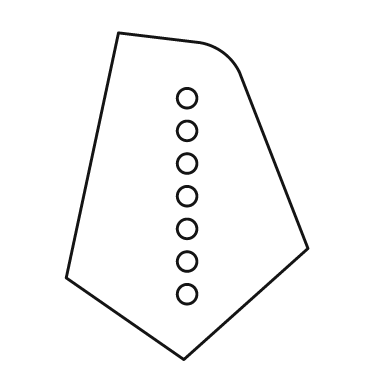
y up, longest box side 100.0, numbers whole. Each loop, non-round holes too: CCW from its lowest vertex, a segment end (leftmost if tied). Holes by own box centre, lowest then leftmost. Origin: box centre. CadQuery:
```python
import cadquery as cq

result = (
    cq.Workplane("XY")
    .moveTo(-1.0, -50.0)
    .lineTo(37.0, -16.0)
    .lineTo(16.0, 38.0)
    .threePointArc((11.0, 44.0), (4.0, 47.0))
    .lineTo(-21.0, 50.0)
    .lineTo(-37.0, -25.0)
    .close()
    .moveTo(0.0, -30.0)
    .circle(3.0)
    .moveTo(0.0, -20.0)
    .circle(3.0)
    .moveTo(0.0, -10.0)
    .circle(3.0)
    .moveTo(0.0, 0.0)
    .circle(3.0)
    .moveTo(0.0, 10.0)
    .circle(3.0)
    .moveTo(0.0, 20.0)
    .circle(3.0)
    .moveTo(0.0, 30.0)
    .circle(3.0)
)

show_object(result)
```